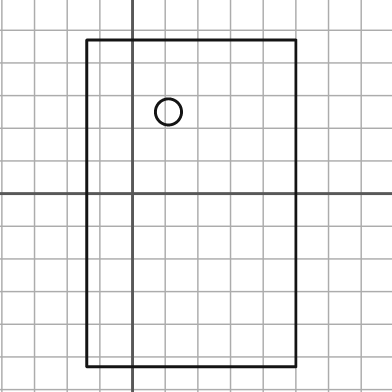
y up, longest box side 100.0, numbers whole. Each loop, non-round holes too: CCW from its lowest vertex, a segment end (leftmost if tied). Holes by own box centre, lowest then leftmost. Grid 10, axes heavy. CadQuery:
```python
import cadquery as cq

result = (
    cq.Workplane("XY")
    .moveTo(-14.0, -53.0)
    .lineTo(50.0, -53.0)
    .lineTo(50.0, 47.0)
    .lineTo(-14.0, 47.0)
    .close()
    .moveTo(11.0, 25.0)
    .circle(4.0)
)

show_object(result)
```